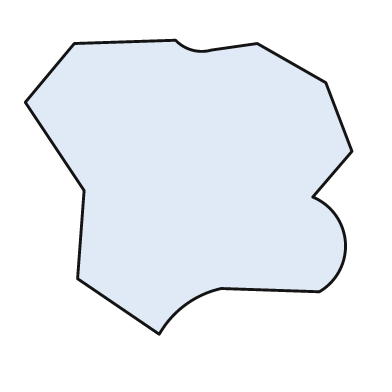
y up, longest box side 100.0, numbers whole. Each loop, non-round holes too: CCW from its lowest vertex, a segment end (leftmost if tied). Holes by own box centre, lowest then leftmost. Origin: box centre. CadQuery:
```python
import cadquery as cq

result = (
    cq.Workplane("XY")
    .moveTo(-9.0, -45.0)
    .threePointArc((-1.0, -36.0), (10.0, -31.0))
    .lineTo(40.0, -32.0)
    .threePointArc((48.0, -17.0), (38.0, -3.0))
    .lineTo(50.0, 11.0)
    .lineTo(42.0, 32.0)
    .lineTo(21.0, 44.0)
    .lineTo(7.0, 42.0)
    .threePointArc((1.0, 42.0), (-4.0, 45.0))
    .lineTo(-35.0, 44.0)
    .lineTo(-50.0, 26.0)
    .lineTo(-32.0, -1.0)
    .lineTo(-34.0, -28.0)
    .close()
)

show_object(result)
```